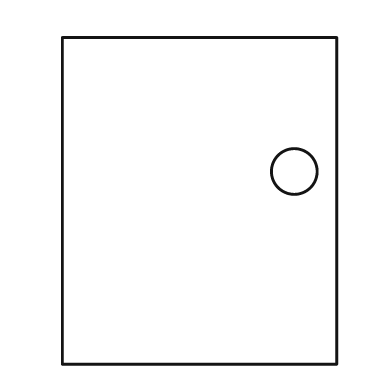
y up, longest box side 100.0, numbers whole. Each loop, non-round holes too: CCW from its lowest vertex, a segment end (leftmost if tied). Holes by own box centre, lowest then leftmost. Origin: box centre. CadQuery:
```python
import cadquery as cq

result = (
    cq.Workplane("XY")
    .moveTo(-42.0, -50.0)
    .lineTo(42.0, -50.0)
    .lineTo(42.0, 50.0)
    .lineTo(-42.0, 50.0)
    .close()
    .moveTo(29.0, 9.0)
    .circle(7.0)
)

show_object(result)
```